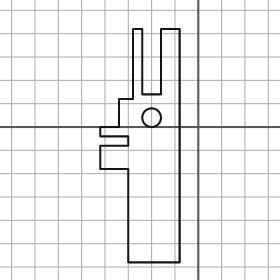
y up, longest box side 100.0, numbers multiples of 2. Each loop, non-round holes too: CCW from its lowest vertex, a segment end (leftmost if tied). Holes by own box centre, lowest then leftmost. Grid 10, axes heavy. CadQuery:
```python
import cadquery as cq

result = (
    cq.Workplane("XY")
    .moveTo(-30.0, -58.0)
    .lineTo(-8.0, -58.0)
    .lineTo(-8.0, 42.0)
    .lineTo(-16.0, 42.0)
    .lineTo(-16.0, 14.0)
    .lineTo(-24.0, 14.0)
    .lineTo(-24.0, 42.0)
    .lineTo(-28.0, 42.0)
    .lineTo(-28.0, 12.0)
    .lineTo(-34.0, 12.0)
    .lineTo(-34.0, 0.0)
    .lineTo(-42.0, 0.0)
    .lineTo(-42.0, -4.0)
    .lineTo(-30.0, -4.0)
    .lineTo(-30.0, -8.0)
    .lineTo(-42.0, -8.0)
    .lineTo(-42.0, -18.0)
    .lineTo(-30.0, -18.0)
    .close()
    .moveTo(-20.0, 4.0)
    .circle(4.0)
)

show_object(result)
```